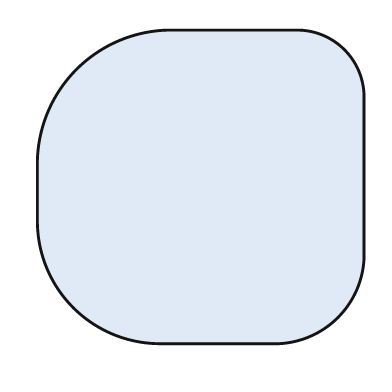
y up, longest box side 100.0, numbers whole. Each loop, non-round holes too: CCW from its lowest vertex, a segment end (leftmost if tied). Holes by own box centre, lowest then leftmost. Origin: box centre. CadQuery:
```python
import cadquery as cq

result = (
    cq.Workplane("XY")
    .moveTo(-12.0, -48.0)
    .lineTo(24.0, -48.0)
    .threePointArc((42.0, -40.0), (50.0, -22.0))
    .lineTo(50.0, 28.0)
    .threePointArc((44.0, 42.0), (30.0, 48.0))
    .lineTo(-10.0, 48.0)
    .threePointArc((-38.0, 36.0), (-50.0, 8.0))
    .lineTo(-50.0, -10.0)
    .threePointArc((-39.0, -37.0), (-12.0, -48.0))
    .close()
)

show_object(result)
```